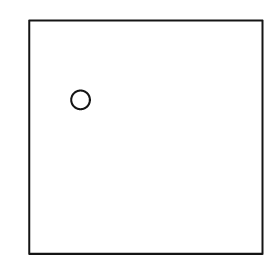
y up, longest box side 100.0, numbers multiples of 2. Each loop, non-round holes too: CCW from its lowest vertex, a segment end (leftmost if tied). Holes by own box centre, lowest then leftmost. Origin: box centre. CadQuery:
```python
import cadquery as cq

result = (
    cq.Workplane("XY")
    .moveTo(-50.0, -50.0)
    .lineTo(50.0, -50.0)
    .lineTo(50.0, 50.0)
    .lineTo(-50.0, 50.0)
    .close()
    .moveTo(-28.0, 16.0)
    .circle(4.0)
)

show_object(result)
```